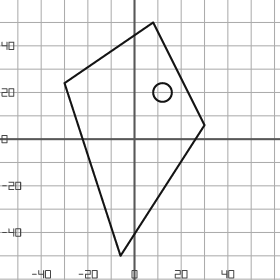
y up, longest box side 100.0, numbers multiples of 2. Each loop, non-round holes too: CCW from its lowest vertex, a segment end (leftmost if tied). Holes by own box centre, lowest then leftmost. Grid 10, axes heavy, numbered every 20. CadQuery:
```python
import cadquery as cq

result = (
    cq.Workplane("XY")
    .moveTo(-6.0, -50.0)
    .lineTo(30.0, 6.0)
    .lineTo(8.0, 50.0)
    .lineTo(-30.0, 24.0)
    .close()
    .moveTo(12.0, 20.0)
    .circle(4.0)
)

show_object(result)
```